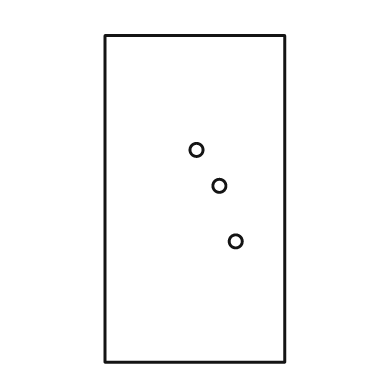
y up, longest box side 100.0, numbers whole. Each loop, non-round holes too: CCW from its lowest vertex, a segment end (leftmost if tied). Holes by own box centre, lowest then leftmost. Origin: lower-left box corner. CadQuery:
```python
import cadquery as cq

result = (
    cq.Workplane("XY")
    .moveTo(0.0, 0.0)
    .lineTo(55.0, 0.0)
    .lineTo(55.0, 100.0)
    .lineTo(0.0, 100.0)
    .close()
    .moveTo(40.0, 37.0)
    .circle(2.0)
    .moveTo(35.0, 54.0)
    .circle(2.0)
    .moveTo(28.0, 65.0)
    .circle(2.0)
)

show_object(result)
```